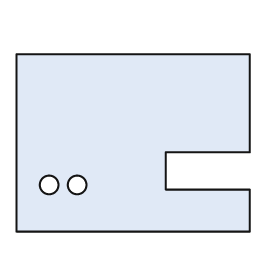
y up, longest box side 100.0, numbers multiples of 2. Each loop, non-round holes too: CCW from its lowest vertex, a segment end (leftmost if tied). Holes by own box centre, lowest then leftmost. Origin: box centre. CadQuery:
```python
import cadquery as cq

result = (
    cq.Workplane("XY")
    .moveTo(-50.0, -38.0)
    .lineTo(50.0, -38.0)
    .lineTo(50.0, -20.0)
    .lineTo(14.0, -20.0)
    .lineTo(14.0, -4.0)
    .lineTo(50.0, -4.0)
    .lineTo(50.0, 38.0)
    .lineTo(-50.0, 38.0)
    .close()
    .moveTo(-36.0, -18.0)
    .circle(4.0)
    .moveTo(-24.0, -18.0)
    .circle(4.0)
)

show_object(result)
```